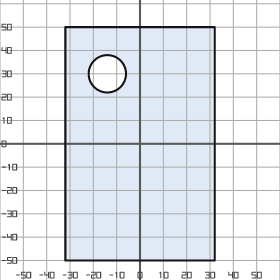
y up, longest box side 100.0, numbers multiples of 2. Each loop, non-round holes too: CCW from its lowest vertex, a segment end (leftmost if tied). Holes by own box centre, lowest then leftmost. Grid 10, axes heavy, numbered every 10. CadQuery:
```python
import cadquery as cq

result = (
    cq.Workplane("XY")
    .moveTo(-32.0, -50.0)
    .lineTo(32.0, -50.0)
    .lineTo(32.0, 50.0)
    .lineTo(-32.0, 50.0)
    .close()
    .moveTo(-14.0, 30.0)
    .circle(8.0)
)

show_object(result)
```